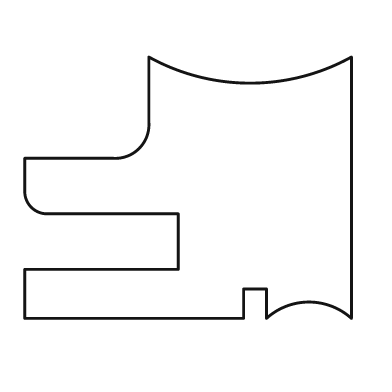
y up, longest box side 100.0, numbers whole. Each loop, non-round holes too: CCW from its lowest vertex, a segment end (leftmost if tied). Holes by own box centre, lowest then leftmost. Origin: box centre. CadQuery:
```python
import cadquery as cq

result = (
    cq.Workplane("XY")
    .moveTo(-50.0, -40.0)
    .lineTo(17.0, -40.0)
    .lineTo(17.0, -31.0)
    .lineTo(24.0, -31.0)
    .lineTo(24.0, -40.0)
    .threePointArc((37.0, -35.0), (50.0, -40.0))
    .lineTo(50.0, 40.0)
    .threePointArc((19.0, 32.0), (-12.0, 40.0))
    .lineTo(-12.0, 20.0)
    .threePointArc((-15.0, 12.0), (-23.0, 9.0))
    .lineTo(-50.0, 9.0)
    .lineTo(-50.0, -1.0)
    .threePointArc((-48.0, -6.0), (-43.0, -8.0))
    .lineTo(-3.0, -8.0)
    .lineTo(-3.0, -25.0)
    .lineTo(-50.0, -25.0)
    .close()
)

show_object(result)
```